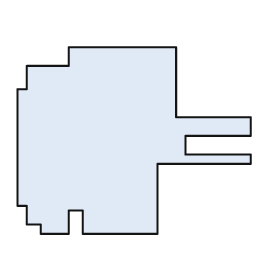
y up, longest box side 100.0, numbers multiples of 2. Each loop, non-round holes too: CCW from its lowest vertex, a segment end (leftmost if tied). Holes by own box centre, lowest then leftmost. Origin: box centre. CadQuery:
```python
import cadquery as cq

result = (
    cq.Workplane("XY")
    .moveTo(-40.0, -40.0)
    .lineTo(-28.0, -40.0)
    .lineTo(-28.0, -30.0)
    .lineTo(-22.0, -30.0)
    .lineTo(-22.0, -40.0)
    .lineTo(10.0, -40.0)
    .lineTo(10.0, -10.0)
    .lineTo(50.0, -10.0)
    .lineTo(50.0, -6.0)
    .lineTo(22.0, -6.0)
    .lineTo(22.0, 2.0)
    .lineTo(50.0, 2.0)
    .lineTo(50.0, 10.0)
    .lineTo(18.0, 10.0)
    .lineTo(18.0, 40.0)
    .lineTo(-28.0, 40.0)
    .lineTo(-28.0, 32.0)
    .lineTo(-46.0, 32.0)
    .lineTo(-46.0, 22.0)
    .lineTo(-50.0, 22.0)
    .lineTo(-50.0, -28.0)
    .lineTo(-46.0, -28.0)
    .lineTo(-46.0, -36.0)
    .lineTo(-40.0, -36.0)
    .close()
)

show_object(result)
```